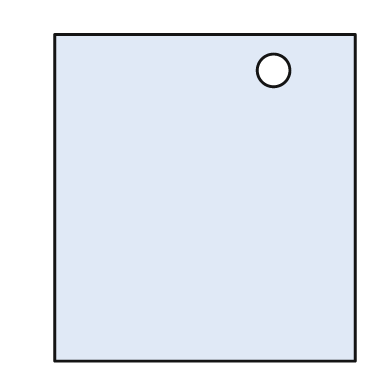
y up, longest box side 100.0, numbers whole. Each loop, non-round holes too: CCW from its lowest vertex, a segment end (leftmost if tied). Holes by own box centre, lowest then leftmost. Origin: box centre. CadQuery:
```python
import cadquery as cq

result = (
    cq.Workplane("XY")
    .moveTo(-46.0, -50.0)
    .lineTo(46.0, -50.0)
    .lineTo(46.0, 50.0)
    .lineTo(-46.0, 50.0)
    .close()
    .moveTo(21.0, 39.0)
    .circle(5.0)
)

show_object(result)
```